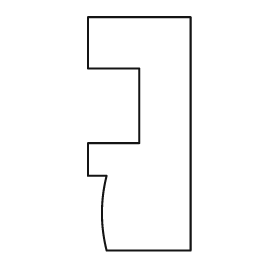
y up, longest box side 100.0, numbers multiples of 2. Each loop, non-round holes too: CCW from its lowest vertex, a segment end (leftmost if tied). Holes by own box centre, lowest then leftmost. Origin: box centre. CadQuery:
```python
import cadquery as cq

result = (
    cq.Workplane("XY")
    .moveTo(-14.0, -50.0)
    .lineTo(22.0, -50.0)
    .lineTo(22.0, 50.0)
    .lineTo(-22.0, 50.0)
    .lineTo(-22.0, 28.0)
    .lineTo(0.0, 28.0)
    .lineTo(0.0, -4.0)
    .lineTo(-22.0, -4.0)
    .lineTo(-22.0, -18.0)
    .lineTo(-14.0, -18.0)
    .threePointArc((-16.0, -34.0), (-14.0, -50.0))
    .close()
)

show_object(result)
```